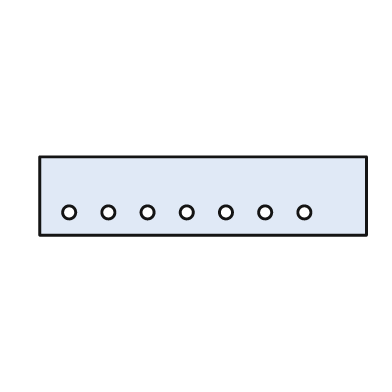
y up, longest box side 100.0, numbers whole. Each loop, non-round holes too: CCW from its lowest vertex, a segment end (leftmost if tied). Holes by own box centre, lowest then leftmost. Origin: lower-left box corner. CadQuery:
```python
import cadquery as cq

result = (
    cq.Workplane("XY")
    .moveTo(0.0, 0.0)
    .lineTo(100.0, 0.0)
    .lineTo(100.0, 24.0)
    .lineTo(0.0, 24.0)
    .close()
    .moveTo(9.0, 7.0)
    .circle(2.0)
    .moveTo(21.0, 7.0)
    .circle(2.0)
    .moveTo(33.0, 7.0)
    .circle(2.0)
    .moveTo(45.0, 7.0)
    .circle(2.0)
    .moveTo(57.0, 7.0)
    .circle(2.0)
    .moveTo(69.0, 7.0)
    .circle(2.0)
    .moveTo(81.0, 7.0)
    .circle(2.0)
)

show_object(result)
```